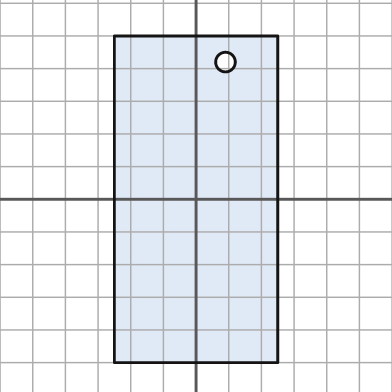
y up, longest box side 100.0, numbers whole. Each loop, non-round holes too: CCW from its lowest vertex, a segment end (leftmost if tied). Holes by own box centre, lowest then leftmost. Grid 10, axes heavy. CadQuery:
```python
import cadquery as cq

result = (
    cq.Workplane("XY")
    .moveTo(-25.0, -50.0)
    .lineTo(25.0, -50.0)
    .lineTo(25.0, 50.0)
    .lineTo(-25.0, 50.0)
    .close()
    .moveTo(9.0, 42.0)
    .circle(3.0)
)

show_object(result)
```